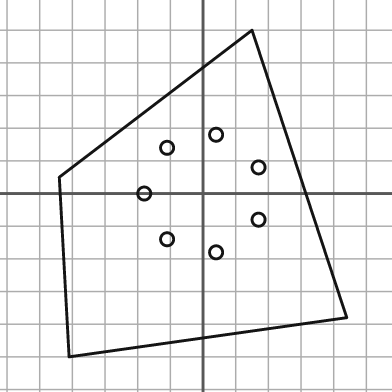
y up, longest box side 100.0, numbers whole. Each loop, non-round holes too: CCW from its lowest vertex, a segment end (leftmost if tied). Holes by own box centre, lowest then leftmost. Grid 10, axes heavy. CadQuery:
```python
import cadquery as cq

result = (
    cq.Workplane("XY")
    .moveTo(-41.0, -50.0)
    .lineTo(44.0, -38.0)
    .lineTo(15.0, 50.0)
    .lineTo(-44.0, 5.0)
    .close()
    .moveTo(4.0, -18.0)
    .circle(2.0)
    .moveTo(-11.0, -14.0)
    .circle(2.0)
    .moveTo(17.0, -8.0)
    .circle(2.0)
    .moveTo(-18.0, 0.0)
    .circle(2.0)
    .moveTo(17.0, 8.0)
    .circle(2.0)
    .moveTo(-11.0, 14.0)
    .circle(2.0)
    .moveTo(4.0, 18.0)
    .circle(2.0)
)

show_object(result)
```